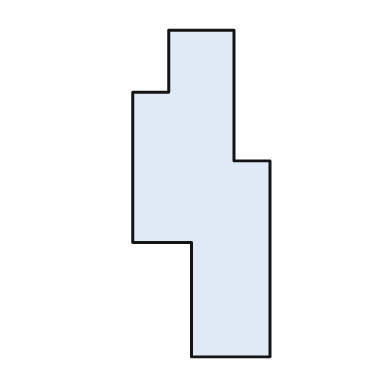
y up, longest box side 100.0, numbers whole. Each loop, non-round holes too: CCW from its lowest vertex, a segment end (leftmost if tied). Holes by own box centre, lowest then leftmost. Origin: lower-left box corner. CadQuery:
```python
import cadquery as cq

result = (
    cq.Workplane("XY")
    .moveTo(18.0, 0.0)
    .lineTo(42.0, 0.0)
    .lineTo(42.0, 60.0)
    .lineTo(31.0, 60.0)
    .lineTo(31.0, 100.0)
    .lineTo(11.0, 100.0)
    .lineTo(11.0, 81.0)
    .lineTo(0.0, 81.0)
    .lineTo(0.0, 35.0)
    .lineTo(18.0, 35.0)
    .close()
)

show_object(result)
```